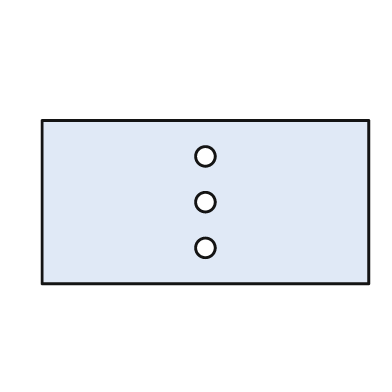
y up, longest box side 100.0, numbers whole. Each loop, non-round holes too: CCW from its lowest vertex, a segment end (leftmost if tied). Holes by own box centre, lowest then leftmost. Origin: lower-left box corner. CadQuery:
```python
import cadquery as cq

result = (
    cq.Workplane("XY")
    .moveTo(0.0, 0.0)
    .lineTo(100.0, 0.0)
    .lineTo(100.0, 50.0)
    .lineTo(0.0, 50.0)
    .close()
    .moveTo(50.0, 11.0)
    .circle(3.0)
    .moveTo(50.0, 25.0)
    .circle(3.0)
    .moveTo(50.0, 39.0)
    .circle(3.0)
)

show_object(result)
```